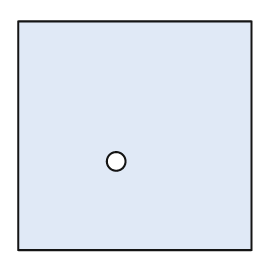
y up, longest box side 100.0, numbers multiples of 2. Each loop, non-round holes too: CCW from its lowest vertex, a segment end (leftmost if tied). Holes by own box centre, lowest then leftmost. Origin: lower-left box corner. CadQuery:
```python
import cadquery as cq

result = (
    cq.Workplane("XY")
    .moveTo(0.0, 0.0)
    .lineTo(100.0, 0.0)
    .lineTo(100.0, 98.0)
    .lineTo(0.0, 98.0)
    .close()
    .moveTo(42.0, 38.0)
    .circle(4.0)
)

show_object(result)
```